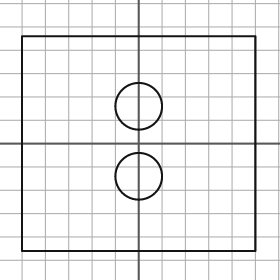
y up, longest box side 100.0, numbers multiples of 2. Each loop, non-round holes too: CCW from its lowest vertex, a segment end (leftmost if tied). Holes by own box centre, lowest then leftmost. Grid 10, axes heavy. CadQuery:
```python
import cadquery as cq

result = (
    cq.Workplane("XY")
    .moveTo(-50.0, -46.0)
    .lineTo(50.0, -46.0)
    .lineTo(50.0, 46.0)
    .lineTo(-50.0, 46.0)
    .close()
    .moveTo(0.0, -14.0)
    .circle(10.0)
    .moveTo(0.0, 16.0)
    .circle(10.0)
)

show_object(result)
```